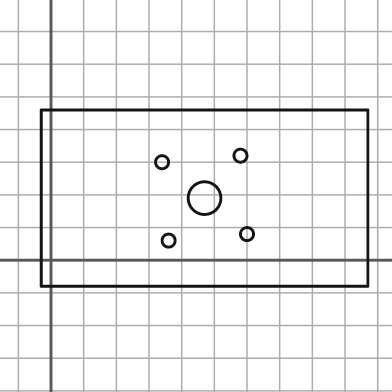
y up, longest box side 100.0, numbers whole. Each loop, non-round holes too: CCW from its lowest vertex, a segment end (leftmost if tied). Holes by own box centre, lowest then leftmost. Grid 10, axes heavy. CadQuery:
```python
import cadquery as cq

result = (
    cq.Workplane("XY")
    .moveTo(-3.0, -8.0)
    .lineTo(97.0, -8.0)
    .lineTo(97.0, 46.0)
    .lineTo(-3.0, 46.0)
    .close()
    .moveTo(36.0, 6.0)
    .circle(2.0)
    .moveTo(60.0, 8.0)
    .circle(2.0)
    .moveTo(47.0, 19.0)
    .circle(5.0)
    .moveTo(34.0, 30.0)
    .circle(2.0)
    .moveTo(58.0, 32.0)
    .circle(2.0)
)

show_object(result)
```